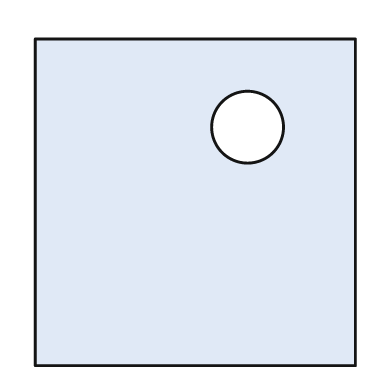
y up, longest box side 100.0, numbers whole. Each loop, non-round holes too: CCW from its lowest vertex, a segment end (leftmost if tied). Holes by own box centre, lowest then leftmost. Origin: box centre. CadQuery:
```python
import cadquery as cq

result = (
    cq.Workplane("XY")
    .moveTo(-49.0, -50.0)
    .lineTo(49.0, -50.0)
    .lineTo(49.0, 50.0)
    .lineTo(-49.0, 50.0)
    .close()
    .moveTo(16.0, 23.0)
    .circle(11.0)
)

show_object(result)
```